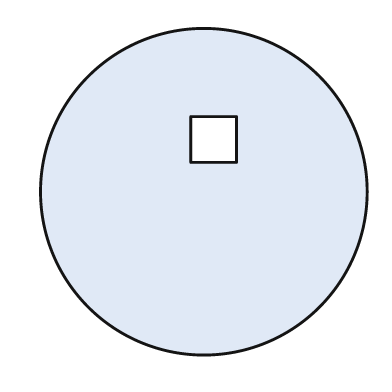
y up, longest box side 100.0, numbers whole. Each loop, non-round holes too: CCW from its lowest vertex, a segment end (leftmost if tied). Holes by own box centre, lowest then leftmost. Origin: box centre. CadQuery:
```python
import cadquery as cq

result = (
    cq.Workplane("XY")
    .moveTo(0.0, 0.0)
    .circle(50.0)
    .moveTo(-4.0, 9.0)
    .lineTo(10.0, 9.0)
    .lineTo(10.0, 23.0)
    .lineTo(-4.0, 23.0)
    .close()
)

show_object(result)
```